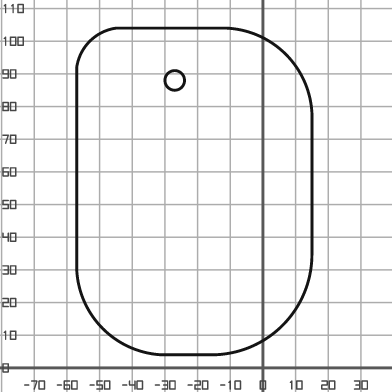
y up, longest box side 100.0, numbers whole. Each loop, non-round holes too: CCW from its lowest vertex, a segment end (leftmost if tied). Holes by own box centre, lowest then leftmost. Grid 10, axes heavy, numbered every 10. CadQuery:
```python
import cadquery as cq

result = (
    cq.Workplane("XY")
    .moveTo(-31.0, 4.0)
    .lineTo(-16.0, 4.0)
    .threePointArc((6.0, 13.0), (15.0, 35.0))
    .lineTo(15.0, 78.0)
    .threePointArc((7.0, 96.0), (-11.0, 104.0))
    .lineTo(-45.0, 104.0)
    .threePointArc((-53.0, 100.0), (-57.0, 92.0))
    .lineTo(-57.0, 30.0)
    .threePointArc((-49.0, 12.0), (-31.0, 4.0))
    .close()
    .moveTo(-27.0, 88.0)
    .circle(3.0)
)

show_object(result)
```